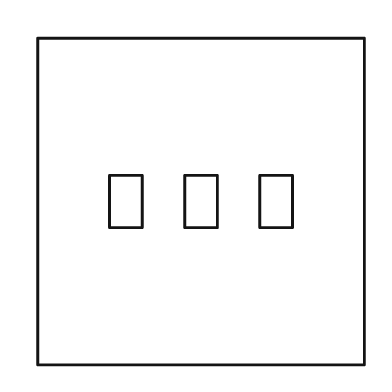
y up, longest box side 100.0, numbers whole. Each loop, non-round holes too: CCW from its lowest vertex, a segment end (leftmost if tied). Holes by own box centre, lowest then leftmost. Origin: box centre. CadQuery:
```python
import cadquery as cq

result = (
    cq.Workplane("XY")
    .moveTo(-50.0, -50.0)
    .lineTo(50.0, -50.0)
    .lineTo(50.0, 50.0)
    .lineTo(-50.0, 50.0)
    .close()
    .moveTo(-28.0, -8.0)
    .lineTo(-18.0, -8.0)
    .lineTo(-18.0, 8.0)
    .lineTo(-28.0, 8.0)
    .close()
    .moveTo(-5.0, -8.0)
    .lineTo(5.0, -8.0)
    .lineTo(5.0, 8.0)
    .lineTo(-5.0, 8.0)
    .close()
    .moveTo(18.0, -8.0)
    .lineTo(28.0, -8.0)
    .lineTo(28.0, 8.0)
    .lineTo(18.0, 8.0)
    .close()
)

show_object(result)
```